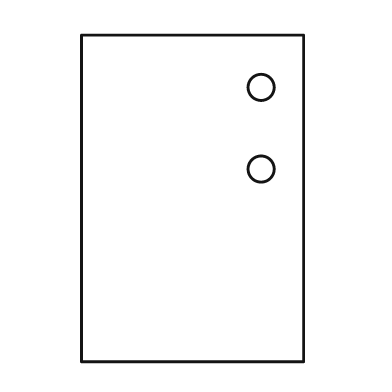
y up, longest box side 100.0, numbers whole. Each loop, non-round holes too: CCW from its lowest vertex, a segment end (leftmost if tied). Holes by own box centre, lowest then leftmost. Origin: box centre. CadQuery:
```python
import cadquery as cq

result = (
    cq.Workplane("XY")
    .moveTo(-34.0, -50.0)
    .lineTo(34.0, -50.0)
    .lineTo(34.0, 50.0)
    .lineTo(-34.0, 50.0)
    .close()
    .moveTo(21.0, 9.0)
    .circle(4.0)
    .moveTo(21.0, 34.0)
    .circle(4.0)
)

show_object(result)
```